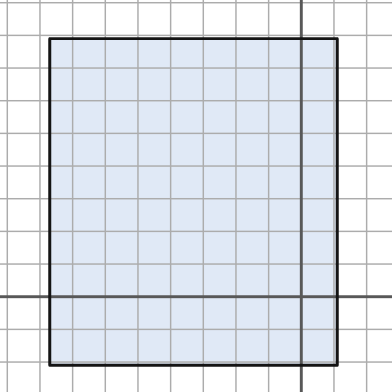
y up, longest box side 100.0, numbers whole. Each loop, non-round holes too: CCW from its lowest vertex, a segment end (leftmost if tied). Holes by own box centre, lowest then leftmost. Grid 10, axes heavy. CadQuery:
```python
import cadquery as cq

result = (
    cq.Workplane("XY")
    .moveTo(-77.0, -21.0)
    .lineTo(11.0, -21.0)
    .lineTo(11.0, 79.0)
    .lineTo(-77.0, 79.0)
    .close()
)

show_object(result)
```